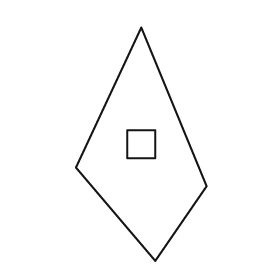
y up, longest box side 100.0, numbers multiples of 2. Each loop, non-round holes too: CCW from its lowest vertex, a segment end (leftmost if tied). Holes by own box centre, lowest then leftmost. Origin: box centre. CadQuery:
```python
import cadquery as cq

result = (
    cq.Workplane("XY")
    .moveTo(6.0, -50.0)
    .lineTo(28.0, -18.0)
    .lineTo(0.0, 50.0)
    .lineTo(-28.0, -10.0)
    .close()
    .moveTo(-6.0, -6.0)
    .lineTo(6.0, -6.0)
    .lineTo(6.0, 6.0)
    .lineTo(-6.0, 6.0)
    .close()
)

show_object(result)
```